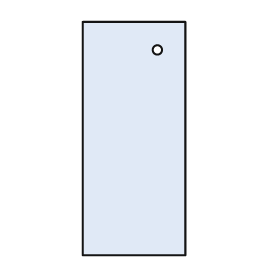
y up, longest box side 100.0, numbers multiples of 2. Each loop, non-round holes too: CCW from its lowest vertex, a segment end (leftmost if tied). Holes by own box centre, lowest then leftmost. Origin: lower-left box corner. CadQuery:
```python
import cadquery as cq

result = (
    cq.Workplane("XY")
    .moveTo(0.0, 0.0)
    .lineTo(44.0, 0.0)
    .lineTo(44.0, 100.0)
    .lineTo(0.0, 100.0)
    .close()
    .moveTo(32.0, 88.0)
    .circle(2.0)
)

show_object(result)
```